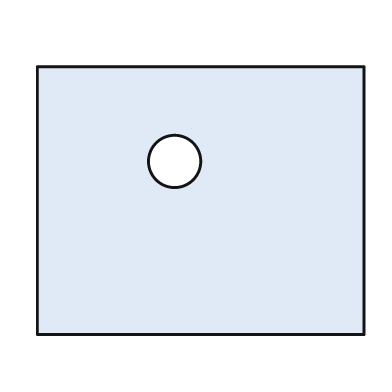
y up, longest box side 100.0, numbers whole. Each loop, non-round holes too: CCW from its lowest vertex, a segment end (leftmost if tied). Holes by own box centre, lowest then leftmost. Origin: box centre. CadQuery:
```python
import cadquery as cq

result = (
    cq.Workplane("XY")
    .moveTo(-50.0, -41.0)
    .lineTo(50.0, -41.0)
    .lineTo(50.0, 41.0)
    .lineTo(-50.0, 41.0)
    .close()
    .moveTo(-8.0, 12.0)
    .circle(8.0)
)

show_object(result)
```